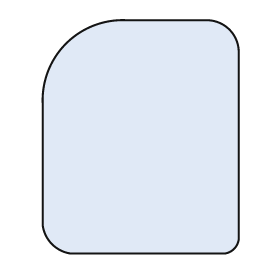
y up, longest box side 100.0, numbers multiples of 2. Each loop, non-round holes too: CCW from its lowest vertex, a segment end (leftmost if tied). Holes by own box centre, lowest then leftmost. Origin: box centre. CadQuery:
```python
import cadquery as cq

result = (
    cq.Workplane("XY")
    .moveTo(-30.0, -50.0)
    .lineTo(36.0, -50.0)
    .threePointArc((40.0, -48.0), (42.0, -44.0))
    .lineTo(42.0, 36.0)
    .threePointArc((38.0, 46.0), (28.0, 50.0))
    .lineTo(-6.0, 50.0)
    .threePointArc((-32.0, 40.0), (-42.0, 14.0))
    .lineTo(-42.0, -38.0)
    .threePointArc((-38.0, -46.0), (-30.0, -50.0))
    .close()
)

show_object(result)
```